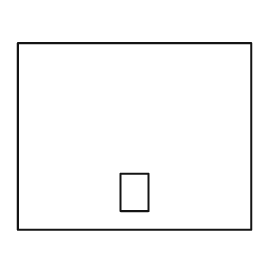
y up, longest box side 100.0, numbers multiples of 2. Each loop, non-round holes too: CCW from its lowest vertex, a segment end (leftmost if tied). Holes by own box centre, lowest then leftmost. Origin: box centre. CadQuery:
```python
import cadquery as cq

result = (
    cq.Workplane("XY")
    .moveTo(-50.0, -40.0)
    .lineTo(50.0, -40.0)
    .lineTo(50.0, 40.0)
    .lineTo(-50.0, 40.0)
    .close()
    .moveTo(-6.0, -32.0)
    .lineTo(6.0, -32.0)
    .lineTo(6.0, -16.0)
    .lineTo(-6.0, -16.0)
    .close()
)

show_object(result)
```